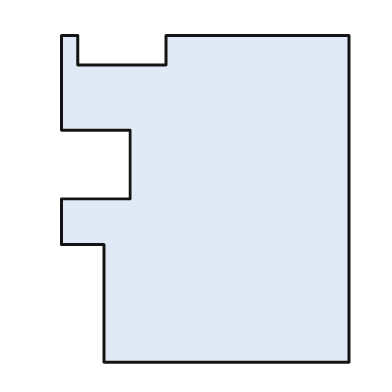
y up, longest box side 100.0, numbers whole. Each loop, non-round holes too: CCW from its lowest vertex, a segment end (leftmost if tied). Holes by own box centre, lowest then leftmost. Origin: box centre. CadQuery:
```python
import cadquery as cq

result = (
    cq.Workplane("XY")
    .moveTo(-31.0, -50.0)
    .lineTo(44.0, -50.0)
    .lineTo(44.0, 50.0)
    .lineTo(-12.0, 50.0)
    .lineTo(-12.0, 41.0)
    .lineTo(-39.0, 41.0)
    .lineTo(-39.0, 50.0)
    .lineTo(-44.0, 50.0)
    .lineTo(-44.0, 21.0)
    .lineTo(-23.0, 21.0)
    .lineTo(-23.0, 0.0)
    .lineTo(-44.0, 0.0)
    .lineTo(-44.0, -14.0)
    .lineTo(-31.0, -14.0)
    .close()
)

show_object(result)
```